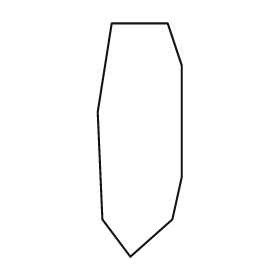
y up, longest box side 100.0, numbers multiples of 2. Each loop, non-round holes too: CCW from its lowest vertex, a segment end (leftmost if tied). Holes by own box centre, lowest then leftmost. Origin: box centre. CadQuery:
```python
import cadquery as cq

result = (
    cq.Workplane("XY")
    .moveTo(-4.0, -50.0)
    .lineTo(14.0, -34.0)
    .lineTo(18.0, -16.0)
    .lineTo(18.0, 32.0)
    .lineTo(12.0, 50.0)
    .lineTo(-12.0, 50.0)
    .lineTo(-18.0, 12.0)
    .lineTo(-16.0, -34.0)
    .close()
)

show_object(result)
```